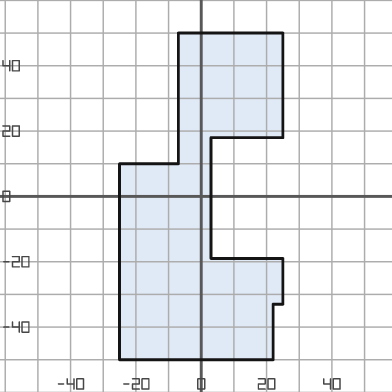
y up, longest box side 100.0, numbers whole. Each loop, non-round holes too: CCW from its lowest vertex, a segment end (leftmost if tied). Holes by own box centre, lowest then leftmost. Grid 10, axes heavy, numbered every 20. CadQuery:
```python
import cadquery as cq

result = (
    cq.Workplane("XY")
    .moveTo(-25.0, -50.0)
    .lineTo(22.0, -50.0)
    .lineTo(22.0, -33.0)
    .lineTo(25.0, -33.0)
    .lineTo(25.0, -19.0)
    .lineTo(3.0, -19.0)
    .lineTo(3.0, 18.0)
    .lineTo(25.0, 18.0)
    .lineTo(25.0, 50.0)
    .lineTo(-7.0, 50.0)
    .lineTo(-7.0, 10.0)
    .lineTo(-25.0, 10.0)
    .close()
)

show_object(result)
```